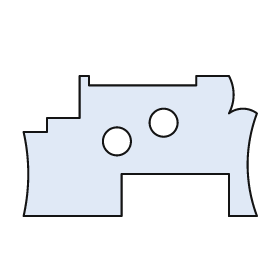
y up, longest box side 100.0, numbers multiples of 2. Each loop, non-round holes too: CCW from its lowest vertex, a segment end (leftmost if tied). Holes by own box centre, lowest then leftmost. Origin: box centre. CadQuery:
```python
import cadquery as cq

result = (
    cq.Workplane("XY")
    .moveTo(-50.0, -30.0)
    .lineTo(-8.0, -30.0)
    .lineTo(-8.0, -12.0)
    .lineTo(38.0, -12.0)
    .lineTo(38.0, -30.0)
    .lineTo(50.0, -30.0)
    .threePointArc((46.0, -8.0), (50.0, 14.0))
    .threePointArc((44.0, 16.0), (38.0, 14.0))
    .threePointArc((40.0, 22.0), (38.0, 30.0))
    .lineTo(24.0, 30.0)
    .lineTo(24.0, 26.0)
    .lineTo(-22.0, 26.0)
    .lineTo(-22.0, 30.0)
    .lineTo(-26.0, 30.0)
    .lineTo(-26.0, 12.0)
    .lineTo(-40.0, 12.0)
    .lineTo(-40.0, 6.0)
    .lineTo(-50.0, 6.0)
    .threePointArc((-48.0, -12.0), (-50.0, -30.0))
    .close()
    .moveTo(-10.0, 2.0)
    .circle(6.0)
    .moveTo(10.0, 10.0)
    .circle(6.0)
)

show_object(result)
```